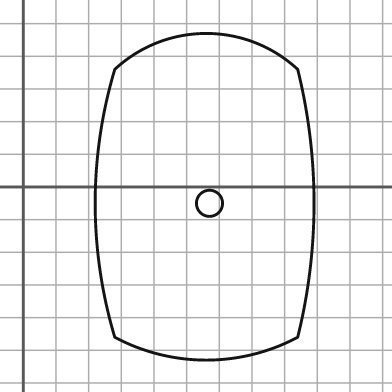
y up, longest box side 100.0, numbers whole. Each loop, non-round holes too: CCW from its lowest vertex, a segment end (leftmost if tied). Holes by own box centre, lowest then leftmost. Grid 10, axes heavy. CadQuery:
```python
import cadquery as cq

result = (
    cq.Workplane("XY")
    .moveTo(28.0, -46.0)
    .threePointArc((56.0, -53.0), (84.0, -46.0))
    .threePointArc((89.0, -5.0), (84.0, 36.0))
    .threePointArc((56.0, 47.0), (28.0, 36.0))
    .threePointArc((22.0, -5.0), (28.0, -46.0))
    .close()
    .moveTo(57.0, -5.0)
    .circle(4.0)
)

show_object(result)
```